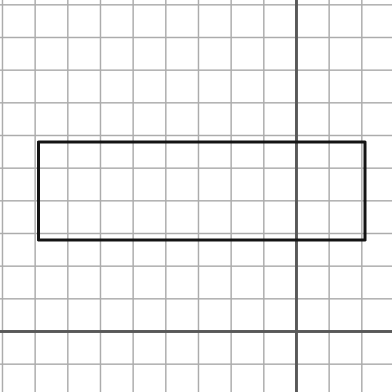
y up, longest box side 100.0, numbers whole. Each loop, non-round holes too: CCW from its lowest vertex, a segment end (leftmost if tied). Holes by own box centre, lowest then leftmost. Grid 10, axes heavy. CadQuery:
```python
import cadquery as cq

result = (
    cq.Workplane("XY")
    .moveTo(-79.0, 28.0)
    .lineTo(21.0, 28.0)
    .lineTo(21.0, 58.0)
    .lineTo(-79.0, 58.0)
    .close()
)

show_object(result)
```